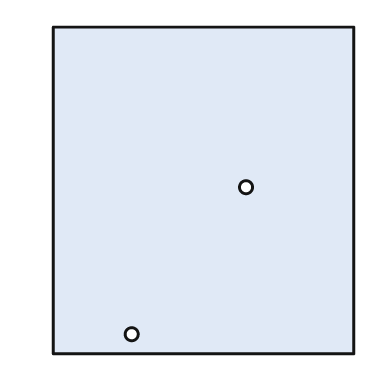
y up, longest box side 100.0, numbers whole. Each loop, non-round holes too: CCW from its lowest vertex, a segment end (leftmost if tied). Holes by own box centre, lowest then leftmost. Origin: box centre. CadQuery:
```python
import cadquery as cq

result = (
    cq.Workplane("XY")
    .moveTo(-46.0, -50.0)
    .lineTo(46.0, -50.0)
    .lineTo(46.0, 50.0)
    .lineTo(-46.0, 50.0)
    .close()
    .moveTo(-22.0, -44.0)
    .circle(2.0)
    .moveTo(13.0, 1.0)
    .circle(2.0)
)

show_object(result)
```